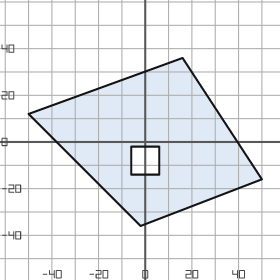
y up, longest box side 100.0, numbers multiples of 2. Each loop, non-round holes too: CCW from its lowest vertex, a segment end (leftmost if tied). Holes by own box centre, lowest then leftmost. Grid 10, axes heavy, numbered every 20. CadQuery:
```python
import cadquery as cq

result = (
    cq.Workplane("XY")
    .moveTo(-2.0, -36.0)
    .lineTo(50.0, -16.0)
    .lineTo(16.0, 36.0)
    .lineTo(-50.0, 12.0)
    .close()
    .moveTo(-6.0, -14.0)
    .lineTo(6.0, -14.0)
    .lineTo(6.0, -2.0)
    .lineTo(-6.0, -2.0)
    .close()
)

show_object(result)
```